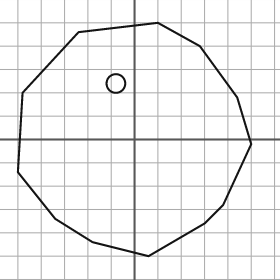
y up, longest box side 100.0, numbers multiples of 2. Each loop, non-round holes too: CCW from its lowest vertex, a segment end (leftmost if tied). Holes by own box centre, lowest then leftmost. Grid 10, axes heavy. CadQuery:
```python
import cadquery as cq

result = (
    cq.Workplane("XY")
    .moveTo(6.0, -50.0)
    .lineTo(30.0, -36.0)
    .lineTo(38.0, -28.0)
    .lineTo(50.0, -2.0)
    .lineTo(44.0, 18.0)
    .lineTo(28.0, 40.0)
    .lineTo(10.0, 50.0)
    .lineTo(-24.0, 46.0)
    .lineTo(-48.0, 20.0)
    .lineTo(-50.0, -14.0)
    .lineTo(-34.0, -34.0)
    .lineTo(-18.0, -44.0)
    .close()
    .moveTo(-8.0, 24.0)
    .circle(4.0)
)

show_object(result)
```